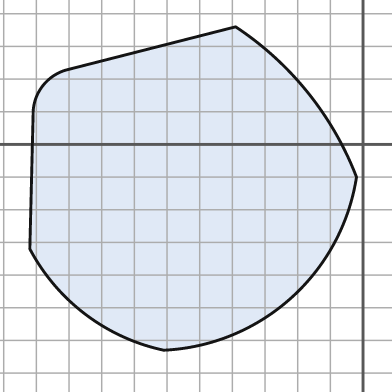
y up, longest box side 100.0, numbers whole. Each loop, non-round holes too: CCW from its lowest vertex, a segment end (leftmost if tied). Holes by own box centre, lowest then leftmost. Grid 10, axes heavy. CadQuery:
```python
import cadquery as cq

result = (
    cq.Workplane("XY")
    .moveTo(-61.0, -63.0)
    .threePointArc((-22.0, -47.0), (-2.0, -10.0))
    .threePointArc((-17.0, 16.0), (-39.0, 36.0))
    .lineTo(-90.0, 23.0)
    .threePointArc((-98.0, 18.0), (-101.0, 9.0))
    .lineTo(-102.0, -32.0)
    .threePointArc((-85.0, -52.0), (-61.0, -63.0))
    .close()
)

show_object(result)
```